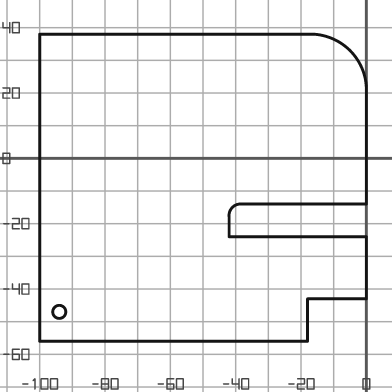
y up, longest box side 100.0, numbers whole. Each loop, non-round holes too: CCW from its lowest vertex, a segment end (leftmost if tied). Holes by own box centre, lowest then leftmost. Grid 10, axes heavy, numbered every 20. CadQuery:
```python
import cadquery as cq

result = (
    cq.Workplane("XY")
    .moveTo(-100.0, -56.0)
    .lineTo(-18.0, -56.0)
    .lineTo(-18.0, -43.0)
    .lineTo(0.0, -43.0)
    .lineTo(0.0, -24.0)
    .lineTo(-42.0, -24.0)
    .lineTo(-42.0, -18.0)
    .threePointArc((-41.0, -15.0), (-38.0, -14.0))
    .lineTo(0.0, -14.0)
    .lineTo(0.0, 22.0)
    .threePointArc((-5.0, 33.0), (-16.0, 38.0))
    .lineTo(-100.0, 38.0)
    .close()
    .moveTo(-94.0, -47.0)
    .circle(2.0)
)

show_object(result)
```